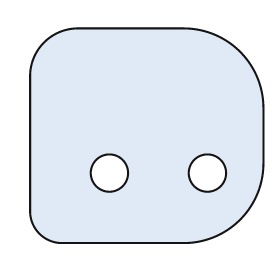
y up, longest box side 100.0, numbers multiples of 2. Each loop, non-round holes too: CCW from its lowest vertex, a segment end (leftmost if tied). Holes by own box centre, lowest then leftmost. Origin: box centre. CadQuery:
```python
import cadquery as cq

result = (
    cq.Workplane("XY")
    .moveTo(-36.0, -46.0)
    .lineTo(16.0, -46.0)
    .threePointArc((40.0, -36.0), (50.0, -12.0))
    .lineTo(50.0, 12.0)
    .threePointArc((40.0, 36.0), (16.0, 46.0))
    .lineTo(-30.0, 46.0)
    .threePointArc((-44.0, 40.0), (-50.0, 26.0))
    .lineTo(-50.0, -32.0)
    .threePointArc((-46.0, -42.0), (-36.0, -46.0))
    .close()
    .moveTo(-16.0, -16.0)
    .circle(8.0)
    .moveTo(26.0, -16.0)
    .circle(8.0)
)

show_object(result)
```